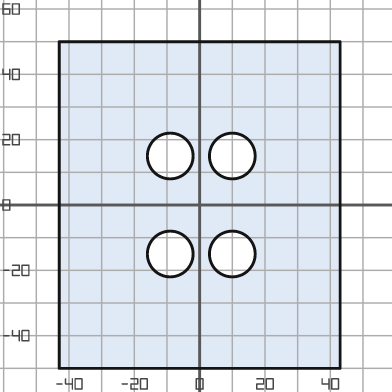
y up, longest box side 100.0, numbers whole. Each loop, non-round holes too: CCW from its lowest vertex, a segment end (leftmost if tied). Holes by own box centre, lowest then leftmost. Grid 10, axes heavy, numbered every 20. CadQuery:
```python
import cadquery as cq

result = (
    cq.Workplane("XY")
    .moveTo(-43.0, -50.0)
    .lineTo(43.0, -50.0)
    .lineTo(43.0, 50.0)
    .lineTo(-43.0, 50.0)
    .close()
    .moveTo(-9.0, -15.0)
    .circle(7.0)
    .moveTo(10.0, -15.0)
    .circle(7.0)
    .moveTo(-9.0, 15.0)
    .circle(7.0)
    .moveTo(10.0, 15.0)
    .circle(7.0)
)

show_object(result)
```